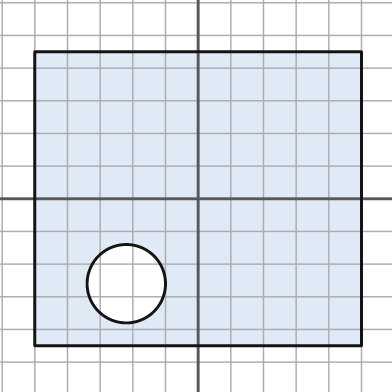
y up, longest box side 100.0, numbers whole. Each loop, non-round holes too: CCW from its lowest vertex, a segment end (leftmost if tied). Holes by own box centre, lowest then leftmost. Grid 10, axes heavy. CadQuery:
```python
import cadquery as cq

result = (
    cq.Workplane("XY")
    .moveTo(-50.0, -45.0)
    .lineTo(50.0, -45.0)
    .lineTo(50.0, 45.0)
    .lineTo(-50.0, 45.0)
    .close()
    .moveTo(-22.0, -26.0)
    .circle(12.0)
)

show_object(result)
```